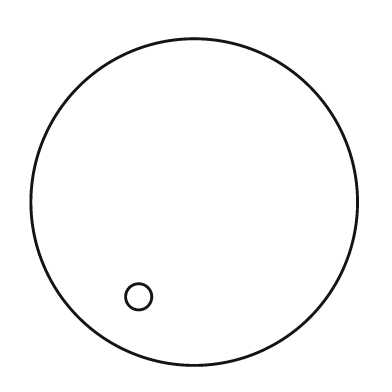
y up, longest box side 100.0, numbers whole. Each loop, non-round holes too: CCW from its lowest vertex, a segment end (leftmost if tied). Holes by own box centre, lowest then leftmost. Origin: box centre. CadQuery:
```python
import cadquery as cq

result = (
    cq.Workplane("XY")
    .moveTo(0.0, 0.0)
    .circle(50.0)
    .moveTo(-17.0, -29.0)
    .circle(4.0)
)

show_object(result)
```